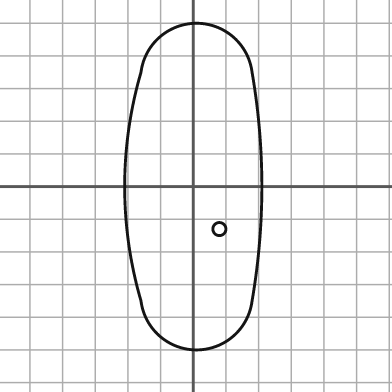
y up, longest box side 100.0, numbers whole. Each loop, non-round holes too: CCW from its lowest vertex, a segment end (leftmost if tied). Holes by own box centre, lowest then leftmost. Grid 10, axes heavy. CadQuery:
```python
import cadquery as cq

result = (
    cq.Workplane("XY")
    .moveTo(-16.0, -35.0)
    .threePointArc((1.0, -50.0), (18.0, -35.0))
    .threePointArc((21.0, 0.0), (18.0, 35.0))
    .threePointArc((1.0, 50.0), (-16.0, 35.0))
    .threePointArc((-21.0, 0.0), (-16.0, -35.0))
    .close()
    .moveTo(8.0, -13.0)
    .circle(2.0)
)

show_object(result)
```